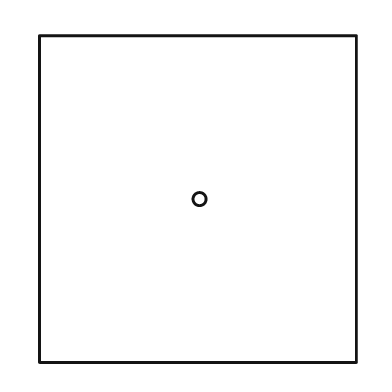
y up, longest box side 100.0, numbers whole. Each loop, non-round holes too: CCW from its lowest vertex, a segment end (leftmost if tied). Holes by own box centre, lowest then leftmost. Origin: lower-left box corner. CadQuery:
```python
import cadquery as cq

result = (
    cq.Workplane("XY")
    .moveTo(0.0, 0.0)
    .lineTo(97.0, 0.0)
    .lineTo(97.0, 100.0)
    .lineTo(0.0, 100.0)
    .close()
    .moveTo(49.0, 50.0)
    .circle(2.0)
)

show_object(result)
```